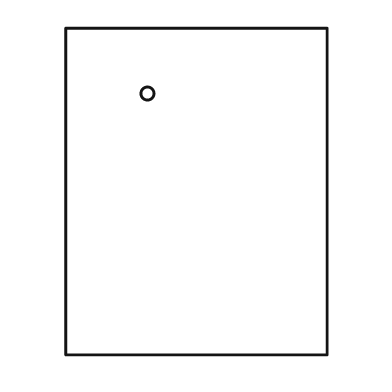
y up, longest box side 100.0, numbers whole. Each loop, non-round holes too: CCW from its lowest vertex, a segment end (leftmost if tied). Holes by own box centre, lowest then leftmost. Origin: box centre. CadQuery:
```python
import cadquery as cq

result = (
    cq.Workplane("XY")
    .moveTo(-40.0, -50.0)
    .lineTo(40.0, -50.0)
    .lineTo(40.0, 50.0)
    .lineTo(-40.0, 50.0)
    .close()
    .moveTo(-15.0, 30.0)
    .circle(2.0)
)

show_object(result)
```